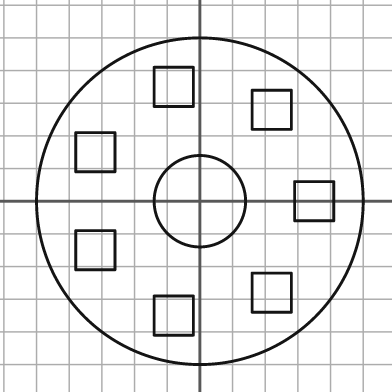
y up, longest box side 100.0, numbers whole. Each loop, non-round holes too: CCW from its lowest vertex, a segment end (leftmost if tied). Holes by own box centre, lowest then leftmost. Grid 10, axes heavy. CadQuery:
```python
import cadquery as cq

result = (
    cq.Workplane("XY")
    .moveTo(0.0, 0.0)
    .circle(50.0)
    .moveTo(-14.0, -41.0)
    .lineTo(-2.0, -41.0)
    .lineTo(-2.0, -29.0)
    .lineTo(-14.0, -29.0)
    .close()
    .moveTo(16.0, -34.0)
    .lineTo(28.0, -34.0)
    .lineTo(28.0, -22.0)
    .lineTo(16.0, -22.0)
    .close()
    .moveTo(-38.0, -21.0)
    .lineTo(-26.0, -21.0)
    .lineTo(-26.0, -9.0)
    .lineTo(-38.0, -9.0)
    .close()
    .moveTo(0.0, 0.0)
    .circle(14.0)
    .moveTo(29.0, -6.0)
    .lineTo(41.0, -6.0)
    .lineTo(41.0, 6.0)
    .lineTo(29.0, 6.0)
    .close()
    .moveTo(-38.0, 9.0)
    .lineTo(-26.0, 9.0)
    .lineTo(-26.0, 21.0)
    .lineTo(-38.0, 21.0)
    .close()
    .moveTo(16.0, 22.0)
    .lineTo(28.0, 22.0)
    .lineTo(28.0, 34.0)
    .lineTo(16.0, 34.0)
    .close()
    .moveTo(-14.0, 29.0)
    .lineTo(-2.0, 29.0)
    .lineTo(-2.0, 41.0)
    .lineTo(-14.0, 41.0)
    .close()
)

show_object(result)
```